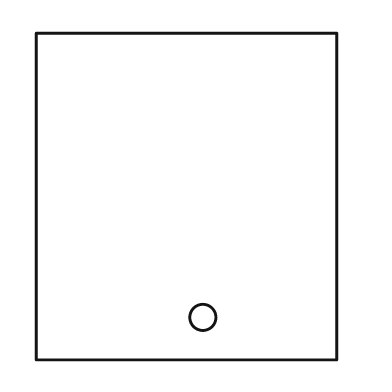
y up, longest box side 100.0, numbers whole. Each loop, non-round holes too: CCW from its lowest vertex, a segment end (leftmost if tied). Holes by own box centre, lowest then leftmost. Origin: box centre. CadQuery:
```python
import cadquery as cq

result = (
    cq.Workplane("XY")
    .moveTo(-46.0, -50.0)
    .lineTo(46.0, -50.0)
    .lineTo(46.0, 50.0)
    .lineTo(-46.0, 50.0)
    .close()
    .moveTo(5.0, -37.0)
    .circle(4.0)
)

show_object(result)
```